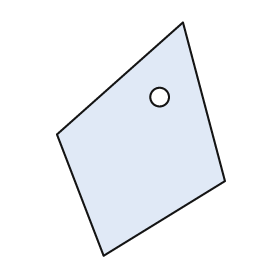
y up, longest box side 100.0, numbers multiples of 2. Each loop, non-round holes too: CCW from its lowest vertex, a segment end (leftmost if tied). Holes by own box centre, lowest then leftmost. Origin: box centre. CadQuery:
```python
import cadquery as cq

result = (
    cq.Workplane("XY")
    .moveTo(-16.0, -50.0)
    .lineTo(36.0, -18.0)
    .lineTo(18.0, 50.0)
    .lineTo(-36.0, 2.0)
    .close()
    .moveTo(8.0, 18.0)
    .circle(4.0)
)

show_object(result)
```